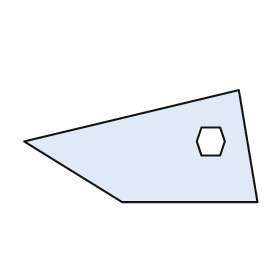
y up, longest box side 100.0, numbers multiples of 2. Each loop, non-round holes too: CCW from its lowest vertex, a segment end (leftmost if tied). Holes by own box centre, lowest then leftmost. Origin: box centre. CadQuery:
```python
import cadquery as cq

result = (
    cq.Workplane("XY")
    .moveTo(-8.0, -24.0)
    .lineTo(50.0, -24.0)
    .lineTo(42.0, 24.0)
    .lineTo(-50.0, 2.0)
    .close()
    .moveTo(26.0, -4.0)
    .lineTo(34.0, -4.0)
    .lineTo(36.0, 2.0)
    .lineTo(34.0, 8.0)
    .lineTo(26.0, 8.0)
    .lineTo(24.0, 2.0)
    .close()
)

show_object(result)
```